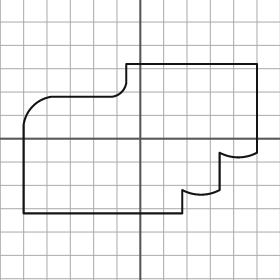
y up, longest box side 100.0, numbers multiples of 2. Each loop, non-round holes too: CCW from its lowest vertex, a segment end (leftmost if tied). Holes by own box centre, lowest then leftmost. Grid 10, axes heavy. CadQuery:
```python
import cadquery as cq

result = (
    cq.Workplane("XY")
    .moveTo(-50.0, -32.0)
    .lineTo(18.0, -32.0)
    .lineTo(18.0, -22.0)
    .threePointArc((26.0, -24.0), (34.0, -22.0))
    .lineTo(34.0, -6.0)
    .threePointArc((42.0, -8.0), (50.0, -6.0))
    .lineTo(50.0, 32.0)
    .lineTo(-6.0, 32.0)
    .lineTo(-6.0, 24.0)
    .threePointArc((-8.0, 20.0), (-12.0, 18.0))
    .lineTo(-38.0, 18.0)
    .threePointArc((-46.0, 14.0), (-50.0, 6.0))
    .close()
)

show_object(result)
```